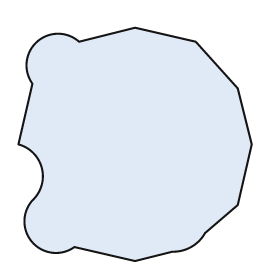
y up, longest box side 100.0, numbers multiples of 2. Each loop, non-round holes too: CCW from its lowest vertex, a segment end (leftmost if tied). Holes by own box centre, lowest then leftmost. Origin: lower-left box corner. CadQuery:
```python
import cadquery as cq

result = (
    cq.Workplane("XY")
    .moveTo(50.0, 0.0)
    .lineTo(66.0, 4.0)
    .threePointArc((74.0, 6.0), (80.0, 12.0))
    .lineTo(94.0, 24.0)
    .lineTo(100.0, 50.0)
    .lineTo(94.0, 74.0)
    .lineTo(76.0, 94.0)
    .lineTo(50.0, 100.0)
    .lineTo(26.0, 94.0)
    .threePointArc((8.0, 94.0), (6.0, 76.0))
    .lineTo(0.0, 50.0)
    .threePointArc((10.0, 40.0), (6.0, 26.0))
    .threePointArc((6.0, 8.0), (24.0, 6.0))
    .close()
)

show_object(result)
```